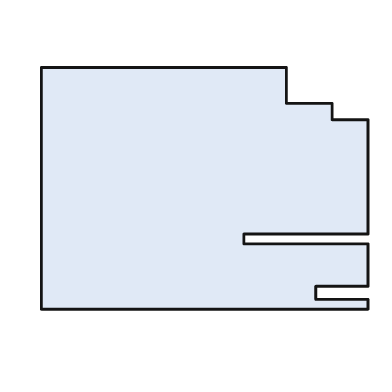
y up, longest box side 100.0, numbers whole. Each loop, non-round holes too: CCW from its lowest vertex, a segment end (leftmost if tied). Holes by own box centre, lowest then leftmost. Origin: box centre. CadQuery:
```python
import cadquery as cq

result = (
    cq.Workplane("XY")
    .moveTo(-50.0, -37.0)
    .lineTo(50.0, -37.0)
    .lineTo(50.0, -34.0)
    .lineTo(34.0, -34.0)
    .lineTo(34.0, -30.0)
    .lineTo(50.0, -30.0)
    .lineTo(50.0, -17.0)
    .lineTo(12.0, -17.0)
    .lineTo(12.0, -14.0)
    .lineTo(50.0, -14.0)
    .lineTo(50.0, 21.0)
    .lineTo(39.0, 21.0)
    .lineTo(39.0, 26.0)
    .lineTo(25.0, 26.0)
    .lineTo(25.0, 37.0)
    .lineTo(-50.0, 37.0)
    .close()
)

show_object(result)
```